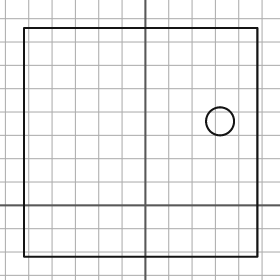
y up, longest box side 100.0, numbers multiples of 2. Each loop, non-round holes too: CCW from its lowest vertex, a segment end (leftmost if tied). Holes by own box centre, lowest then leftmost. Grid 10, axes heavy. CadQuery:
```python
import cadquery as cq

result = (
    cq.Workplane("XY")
    .moveTo(-52.0, -22.0)
    .lineTo(48.0, -22.0)
    .lineTo(48.0, 76.0)
    .lineTo(-52.0, 76.0)
    .close()
    .moveTo(32.0, 36.0)
    .circle(6.0)
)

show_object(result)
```